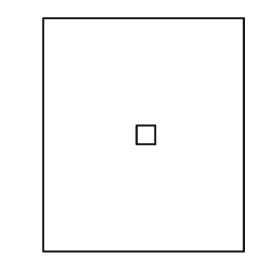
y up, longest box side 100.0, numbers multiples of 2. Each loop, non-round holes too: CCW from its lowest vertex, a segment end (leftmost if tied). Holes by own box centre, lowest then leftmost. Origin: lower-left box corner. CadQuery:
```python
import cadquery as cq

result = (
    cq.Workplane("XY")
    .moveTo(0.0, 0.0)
    .lineTo(86.0, 0.0)
    .lineTo(86.0, 100.0)
    .lineTo(0.0, 100.0)
    .close()
    .moveTo(40.0, 46.0)
    .lineTo(48.0, 46.0)
    .lineTo(48.0, 54.0)
    .lineTo(40.0, 54.0)
    .close()
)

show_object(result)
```